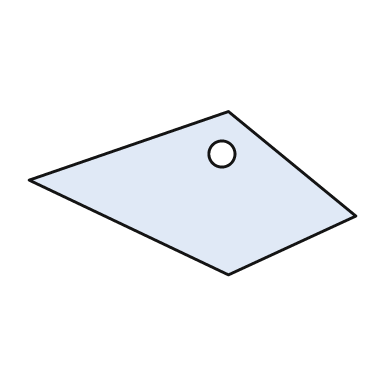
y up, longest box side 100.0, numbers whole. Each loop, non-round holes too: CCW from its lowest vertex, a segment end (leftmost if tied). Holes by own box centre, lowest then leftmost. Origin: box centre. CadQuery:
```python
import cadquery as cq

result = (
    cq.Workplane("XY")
    .moveTo(11.0, -25.0)
    .lineTo(50.0, -7.0)
    .lineTo(11.0, 25.0)
    .lineTo(-50.0, 4.0)
    .close()
    .moveTo(9.0, 12.0)
    .circle(4.0)
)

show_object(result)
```